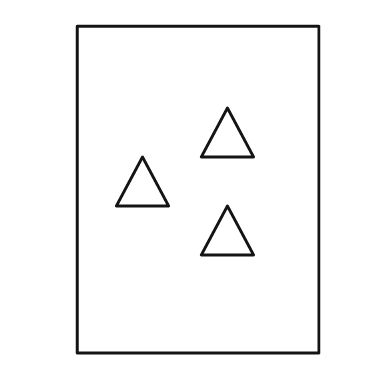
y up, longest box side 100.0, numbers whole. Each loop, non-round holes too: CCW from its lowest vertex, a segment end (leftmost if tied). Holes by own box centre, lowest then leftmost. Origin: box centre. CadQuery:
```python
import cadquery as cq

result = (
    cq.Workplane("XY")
    .moveTo(-37.0, -50.0)
    .lineTo(37.0, -50.0)
    .lineTo(37.0, 50.0)
    .lineTo(-37.0, 50.0)
    .close()
    .moveTo(1.0, -20.0)
    .lineTo(17.0, -20.0)
    .lineTo(9.0, -5.0)
    .close()
    .moveTo(-25.0, -5.0)
    .lineTo(-9.0, -5.0)
    .lineTo(-17.0, 10.0)
    .close()
    .moveTo(1.0, 10.0)
    .lineTo(17.0, 10.0)
    .lineTo(9.0, 25.0)
    .close()
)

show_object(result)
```